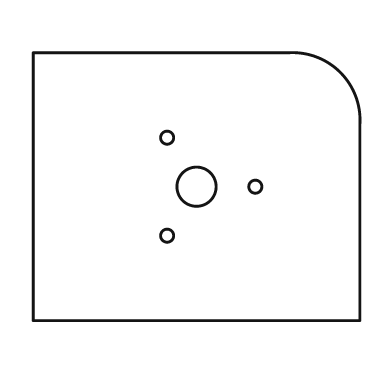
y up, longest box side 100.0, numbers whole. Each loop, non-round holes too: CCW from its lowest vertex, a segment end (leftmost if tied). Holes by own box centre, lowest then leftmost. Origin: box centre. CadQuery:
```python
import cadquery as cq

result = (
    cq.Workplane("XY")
    .moveTo(-50.0, -41.0)
    .lineTo(50.0, -41.0)
    .lineTo(50.0, 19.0)
    .threePointArc((44.0, 35.0), (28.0, 41.0))
    .lineTo(-50.0, 41.0)
    .close()
    .moveTo(-9.0, -15.0)
    .circle(2.0)
    .moveTo(0.0, 0.0)
    .circle(6.0)
    .moveTo(18.0, 0.0)
    .circle(2.0)
    .moveTo(-9.0, 15.0)
    .circle(2.0)
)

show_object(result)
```